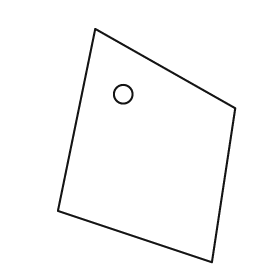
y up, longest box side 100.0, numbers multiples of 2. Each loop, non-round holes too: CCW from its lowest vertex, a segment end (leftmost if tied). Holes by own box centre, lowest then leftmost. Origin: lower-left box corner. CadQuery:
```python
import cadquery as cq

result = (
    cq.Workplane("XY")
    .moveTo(66.0, 0.0)
    .lineTo(76.0, 66.0)
    .lineTo(16.0, 100.0)
    .lineTo(0.0, 22.0)
    .close()
    .moveTo(28.0, 72.0)
    .circle(4.0)
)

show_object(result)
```